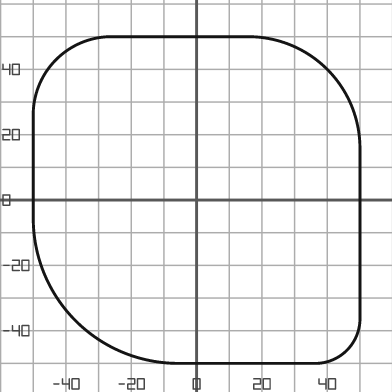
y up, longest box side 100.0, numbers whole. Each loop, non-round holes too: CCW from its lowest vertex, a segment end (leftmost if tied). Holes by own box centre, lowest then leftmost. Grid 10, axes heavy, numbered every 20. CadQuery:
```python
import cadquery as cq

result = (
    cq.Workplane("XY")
    .moveTo(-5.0, -50.0)
    .lineTo(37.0, -50.0)
    .threePointArc((46.0, -46.0), (50.0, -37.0))
    .lineTo(50.0, 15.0)
    .threePointArc((40.0, 40.0), (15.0, 50.0))
    .lineTo(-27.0, 50.0)
    .threePointArc((-43.0, 43.0), (-50.0, 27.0))
    .lineTo(-50.0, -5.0)
    .threePointArc((-37.0, -37.0), (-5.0, -50.0))
    .close()
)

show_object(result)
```